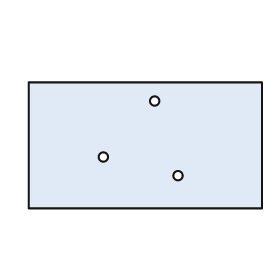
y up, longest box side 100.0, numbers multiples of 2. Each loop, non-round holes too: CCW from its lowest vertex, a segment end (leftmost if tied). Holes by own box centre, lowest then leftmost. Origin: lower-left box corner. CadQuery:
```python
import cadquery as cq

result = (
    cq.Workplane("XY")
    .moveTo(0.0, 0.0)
    .lineTo(100.0, 0.0)
    .lineTo(100.0, 54.0)
    .lineTo(0.0, 54.0)
    .close()
    .moveTo(64.0, 14.0)
    .circle(2.0)
    .moveTo(32.0, 22.0)
    .circle(2.0)
    .moveTo(54.0, 46.0)
    .circle(2.0)
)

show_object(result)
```